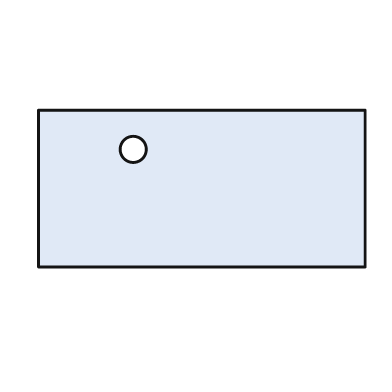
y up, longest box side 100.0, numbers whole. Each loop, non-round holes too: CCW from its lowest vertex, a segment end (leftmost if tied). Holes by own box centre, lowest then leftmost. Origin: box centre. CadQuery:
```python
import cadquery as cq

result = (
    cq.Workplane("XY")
    .moveTo(-50.0, -24.0)
    .lineTo(50.0, -24.0)
    .lineTo(50.0, 24.0)
    .lineTo(-50.0, 24.0)
    .close()
    .moveTo(-21.0, 12.0)
    .circle(4.0)
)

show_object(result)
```